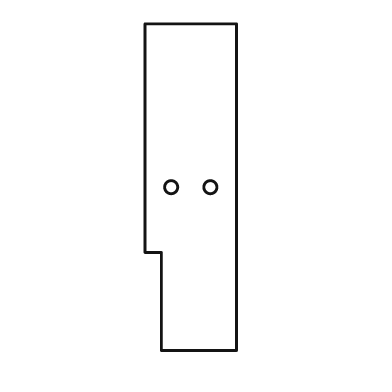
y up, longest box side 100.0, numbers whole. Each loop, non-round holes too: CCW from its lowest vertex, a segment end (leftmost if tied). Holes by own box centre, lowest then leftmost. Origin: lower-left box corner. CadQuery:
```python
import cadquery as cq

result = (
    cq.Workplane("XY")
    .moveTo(5.0, 0.0)
    .lineTo(28.0, 0.0)
    .lineTo(28.0, 100.0)
    .lineTo(0.0, 100.0)
    .lineTo(0.0, 30.0)
    .lineTo(5.0, 30.0)
    .close()
    .moveTo(8.0, 50.0)
    .circle(2.0)
    .moveTo(20.0, 50.0)
    .circle(2.0)
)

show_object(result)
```